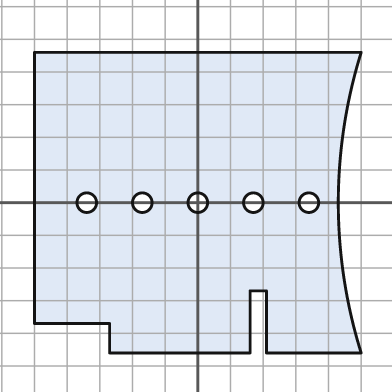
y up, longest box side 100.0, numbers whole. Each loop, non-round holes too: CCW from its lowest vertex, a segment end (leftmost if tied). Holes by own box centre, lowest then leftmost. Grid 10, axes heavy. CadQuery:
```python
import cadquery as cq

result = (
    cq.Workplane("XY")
    .moveTo(-27.0, -46.0)
    .lineTo(16.0, -46.0)
    .lineTo(16.0, -27.0)
    .lineTo(21.0, -27.0)
    .lineTo(21.0, -46.0)
    .lineTo(50.0, -46.0)
    .threePointArc((43.0, 0.0), (50.0, 46.0))
    .lineTo(-50.0, 46.0)
    .lineTo(-50.0, -37.0)
    .lineTo(-27.0, -37.0)
    .close()
    .moveTo(-34.0, 0.0)
    .circle(3.0)
    .moveTo(-17.0, 0.0)
    .circle(3.0)
    .moveTo(0.0, 0.0)
    .circle(3.0)
    .moveTo(17.0, 0.0)
    .circle(3.0)
    .moveTo(34.0, 0.0)
    .circle(3.0)
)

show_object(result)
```